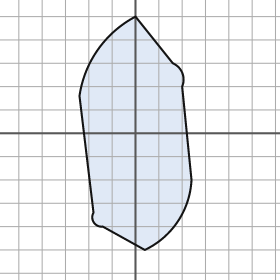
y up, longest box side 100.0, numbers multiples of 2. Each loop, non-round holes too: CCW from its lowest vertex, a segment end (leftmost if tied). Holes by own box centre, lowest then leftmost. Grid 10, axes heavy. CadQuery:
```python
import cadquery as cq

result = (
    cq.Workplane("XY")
    .moveTo(4.0, -50.0)
    .threePointArc((18.0, -38.0), (24.0, -20.0))
    .lineTo(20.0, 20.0)
    .threePointArc((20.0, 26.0), (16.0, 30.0))
    .lineTo(0.0, 50.0)
    .threePointArc((-16.0, 36.0), (-24.0, 16.0))
    .lineTo(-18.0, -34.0)
    .threePointArc((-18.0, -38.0), (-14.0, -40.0))
    .close()
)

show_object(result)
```